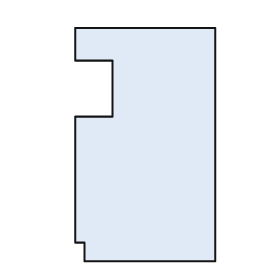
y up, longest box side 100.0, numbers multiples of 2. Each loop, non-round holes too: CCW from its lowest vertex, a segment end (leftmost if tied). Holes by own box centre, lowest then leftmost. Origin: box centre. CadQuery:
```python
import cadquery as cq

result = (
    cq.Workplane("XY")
    .moveTo(-26.0, -50.0)
    .lineTo(30.0, -50.0)
    .lineTo(30.0, 50.0)
    .lineTo(-30.0, 50.0)
    .lineTo(-30.0, 36.0)
    .lineTo(-14.0, 36.0)
    .lineTo(-14.0, 12.0)
    .lineTo(-30.0, 12.0)
    .lineTo(-30.0, -42.0)
    .lineTo(-26.0, -42.0)
    .close()
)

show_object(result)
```